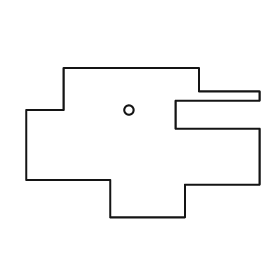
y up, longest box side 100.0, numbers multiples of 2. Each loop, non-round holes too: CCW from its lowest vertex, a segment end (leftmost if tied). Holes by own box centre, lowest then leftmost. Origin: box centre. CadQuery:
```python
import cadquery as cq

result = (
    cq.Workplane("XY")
    .moveTo(-14.0, -32.0)
    .lineTo(18.0, -32.0)
    .lineTo(18.0, -18.0)
    .lineTo(50.0, -18.0)
    .lineTo(50.0, 6.0)
    .lineTo(14.0, 6.0)
    .lineTo(14.0, 18.0)
    .lineTo(50.0, 18.0)
    .lineTo(50.0, 22.0)
    .lineTo(24.0, 22.0)
    .lineTo(24.0, 32.0)
    .lineTo(-34.0, 32.0)
    .lineTo(-34.0, 14.0)
    .lineTo(-50.0, 14.0)
    .lineTo(-50.0, -16.0)
    .lineTo(-14.0, -16.0)
    .close()
    .moveTo(-6.0, 14.0)
    .circle(2.0)
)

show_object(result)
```